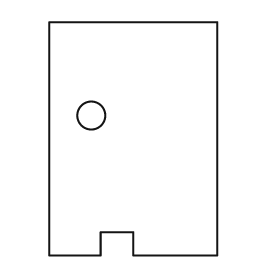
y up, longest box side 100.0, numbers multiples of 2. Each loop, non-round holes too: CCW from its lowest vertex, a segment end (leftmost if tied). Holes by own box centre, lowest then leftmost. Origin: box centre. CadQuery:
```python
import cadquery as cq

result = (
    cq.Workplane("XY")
    .moveTo(-36.0, -50.0)
    .lineTo(-14.0, -50.0)
    .lineTo(-14.0, -40.0)
    .lineTo(0.0, -40.0)
    .lineTo(0.0, -50.0)
    .lineTo(36.0, -50.0)
    .lineTo(36.0, 50.0)
    .lineTo(-36.0, 50.0)
    .close()
    .moveTo(-18.0, 10.0)
    .circle(6.0)
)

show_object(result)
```